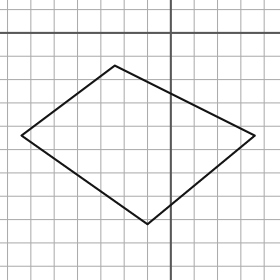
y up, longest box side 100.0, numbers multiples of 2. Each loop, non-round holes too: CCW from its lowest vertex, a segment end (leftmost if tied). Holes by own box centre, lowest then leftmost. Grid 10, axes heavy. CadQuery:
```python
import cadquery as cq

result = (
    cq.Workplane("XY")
    .moveTo(-10.0, -82.0)
    .lineTo(36.0, -44.0)
    .lineTo(-24.0, -14.0)
    .lineTo(-64.0, -44.0)
    .close()
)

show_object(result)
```